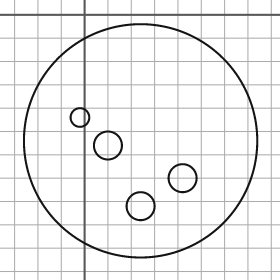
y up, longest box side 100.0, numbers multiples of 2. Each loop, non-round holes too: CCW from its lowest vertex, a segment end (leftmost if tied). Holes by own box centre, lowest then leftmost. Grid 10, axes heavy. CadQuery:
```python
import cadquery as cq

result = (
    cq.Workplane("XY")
    .moveTo(24.0, -54.0)
    .circle(50.0)
    .moveTo(24.0, -82.0)
    .circle(6.0)
    .moveTo(42.0, -70.0)
    .circle(6.0)
    .moveTo(10.0, -56.0)
    .circle(6.0)
    .moveTo(-2.0, -44.0)
    .circle(4.0)
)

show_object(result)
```